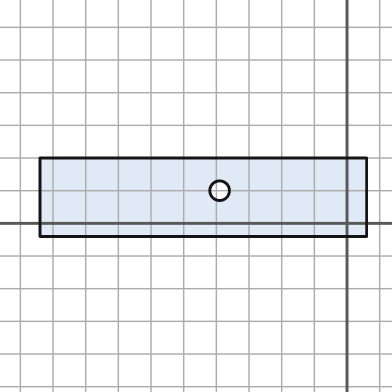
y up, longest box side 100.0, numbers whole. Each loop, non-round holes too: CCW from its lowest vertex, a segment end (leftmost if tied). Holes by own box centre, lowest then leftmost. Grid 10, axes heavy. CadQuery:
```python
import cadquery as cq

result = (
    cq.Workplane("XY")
    .moveTo(-94.0, -4.0)
    .lineTo(6.0, -4.0)
    .lineTo(6.0, 20.0)
    .lineTo(-94.0, 20.0)
    .close()
    .moveTo(-39.0, 10.0)
    .circle(3.0)
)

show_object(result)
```